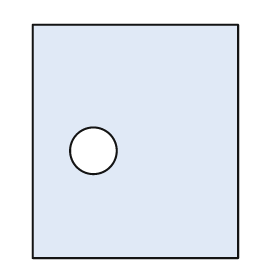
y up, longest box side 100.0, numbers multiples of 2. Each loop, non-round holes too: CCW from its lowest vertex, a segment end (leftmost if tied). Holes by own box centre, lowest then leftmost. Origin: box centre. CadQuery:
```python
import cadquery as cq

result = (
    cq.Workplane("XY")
    .moveTo(-44.0, -50.0)
    .lineTo(44.0, -50.0)
    .lineTo(44.0, 50.0)
    .lineTo(-44.0, 50.0)
    .close()
    .moveTo(-18.0, -4.0)
    .circle(10.0)
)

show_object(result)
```